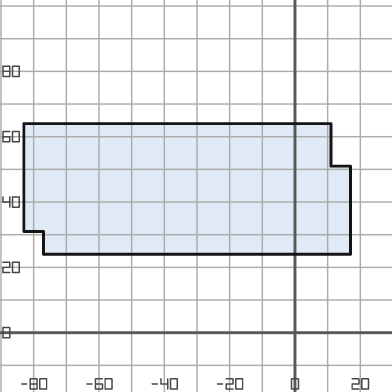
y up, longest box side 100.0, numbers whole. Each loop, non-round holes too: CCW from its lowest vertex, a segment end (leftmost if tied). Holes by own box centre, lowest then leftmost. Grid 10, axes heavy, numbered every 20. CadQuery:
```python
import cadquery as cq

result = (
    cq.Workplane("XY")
    .moveTo(-77.0, 24.0)
    .lineTo(17.0, 24.0)
    .lineTo(17.0, 51.0)
    .lineTo(11.0, 51.0)
    .lineTo(11.0, 64.0)
    .lineTo(-83.0, 64.0)
    .lineTo(-83.0, 31.0)
    .lineTo(-77.0, 31.0)
    .close()
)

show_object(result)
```